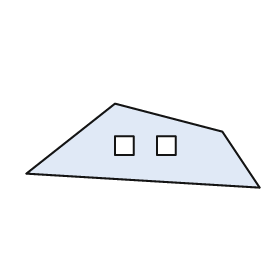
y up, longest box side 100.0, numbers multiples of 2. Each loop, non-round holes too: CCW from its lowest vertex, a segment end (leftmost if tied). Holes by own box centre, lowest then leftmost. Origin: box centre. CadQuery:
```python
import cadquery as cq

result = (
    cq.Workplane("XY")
    .moveTo(50.0, -18.0)
    .lineTo(34.0, 6.0)
    .lineTo(-12.0, 18.0)
    .lineTo(-50.0, -12.0)
    .close()
    .moveTo(-12.0, -4.0)
    .lineTo(-4.0, -4.0)
    .lineTo(-4.0, 4.0)
    .lineTo(-12.0, 4.0)
    .close()
    .moveTo(6.0, -4.0)
    .lineTo(14.0, -4.0)
    .lineTo(14.0, 4.0)
    .lineTo(6.0, 4.0)
    .close()
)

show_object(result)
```